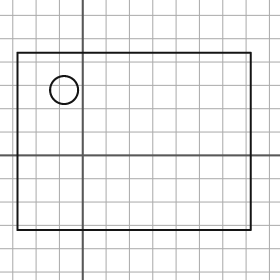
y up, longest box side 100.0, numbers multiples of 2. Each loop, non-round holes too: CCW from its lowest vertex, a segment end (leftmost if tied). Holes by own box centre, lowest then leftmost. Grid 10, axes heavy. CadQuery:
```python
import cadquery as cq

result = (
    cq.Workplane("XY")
    .moveTo(-28.0, -32.0)
    .lineTo(72.0, -32.0)
    .lineTo(72.0, 44.0)
    .lineTo(-28.0, 44.0)
    .close()
    .moveTo(-8.0, 28.0)
    .circle(6.0)
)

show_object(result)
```